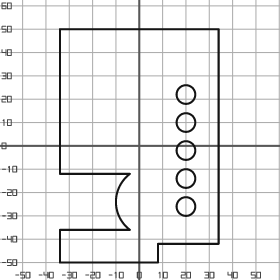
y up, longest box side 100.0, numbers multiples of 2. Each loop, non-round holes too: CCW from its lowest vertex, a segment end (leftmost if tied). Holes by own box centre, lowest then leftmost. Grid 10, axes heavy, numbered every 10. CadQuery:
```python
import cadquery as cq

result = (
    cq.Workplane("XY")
    .moveTo(-34.0, -50.0)
    .lineTo(8.0, -50.0)
    .lineTo(8.0, -42.0)
    .lineTo(34.0, -42.0)
    .lineTo(34.0, 50.0)
    .lineTo(-34.0, 50.0)
    .lineTo(-34.0, -12.0)
    .lineTo(-4.0, -12.0)
    .threePointArc((-10.0, -24.0), (-4.0, -36.0))
    .lineTo(-34.0, -36.0)
    .close()
    .moveTo(20.0, -26.0)
    .circle(4.0)
    .moveTo(20.0, -14.0)
    .circle(4.0)
    .moveTo(20.0, -2.0)
    .circle(4.0)
    .moveTo(20.0, 10.0)
    .circle(4.0)
    .moveTo(20.0, 22.0)
    .circle(4.0)
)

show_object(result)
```